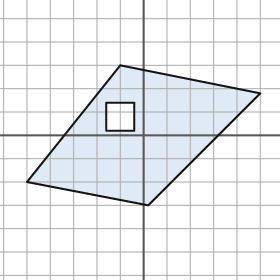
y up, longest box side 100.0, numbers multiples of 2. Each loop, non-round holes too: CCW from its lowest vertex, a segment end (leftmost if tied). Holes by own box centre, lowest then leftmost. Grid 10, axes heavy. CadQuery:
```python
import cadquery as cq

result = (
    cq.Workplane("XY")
    .moveTo(2.0, -30.0)
    .lineTo(50.0, 18.0)
    .lineTo(-10.0, 30.0)
    .lineTo(-50.0, -20.0)
    .close()
    .moveTo(-16.0, 2.0)
    .lineTo(-4.0, 2.0)
    .lineTo(-4.0, 14.0)
    .lineTo(-16.0, 14.0)
    .close()
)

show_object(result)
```